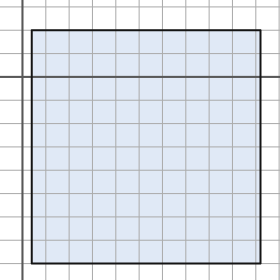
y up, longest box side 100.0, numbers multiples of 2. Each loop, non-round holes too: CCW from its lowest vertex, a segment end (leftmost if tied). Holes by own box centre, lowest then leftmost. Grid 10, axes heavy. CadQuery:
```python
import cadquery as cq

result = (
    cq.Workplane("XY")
    .moveTo(4.0, -80.0)
    .lineTo(102.0, -80.0)
    .lineTo(102.0, 20.0)
    .lineTo(4.0, 20.0)
    .close()
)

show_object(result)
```